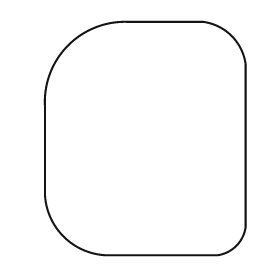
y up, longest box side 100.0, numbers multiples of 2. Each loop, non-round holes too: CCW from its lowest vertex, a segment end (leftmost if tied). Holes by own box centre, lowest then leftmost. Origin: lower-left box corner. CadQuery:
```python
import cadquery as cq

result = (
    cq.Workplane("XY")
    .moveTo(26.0, 0.0)
    .lineTo(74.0, 0.0)
    .threePointArc((82.0, 4.0), (86.0, 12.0))
    .lineTo(86.0, 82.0)
    .threePointArc((80.0, 94.0), (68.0, 100.0))
    .lineTo(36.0, 100.0)
    .threePointArc((10.0, 90.0), (0.0, 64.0))
    .lineTo(0.0, 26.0)
    .threePointArc((8.0, 8.0), (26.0, 0.0))
    .close()
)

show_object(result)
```